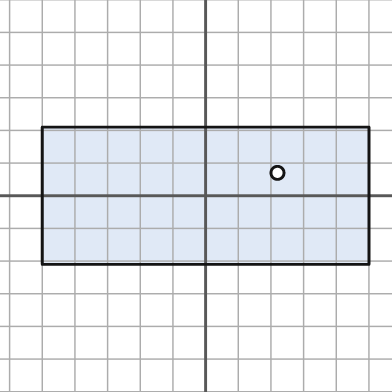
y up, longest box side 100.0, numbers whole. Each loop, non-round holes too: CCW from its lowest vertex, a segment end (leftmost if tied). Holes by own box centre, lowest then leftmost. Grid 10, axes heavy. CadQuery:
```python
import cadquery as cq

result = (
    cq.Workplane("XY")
    .moveTo(-50.0, -21.0)
    .lineTo(50.0, -21.0)
    .lineTo(50.0, 21.0)
    .lineTo(-50.0, 21.0)
    .close()
    .moveTo(22.0, 7.0)
    .circle(2.0)
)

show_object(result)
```